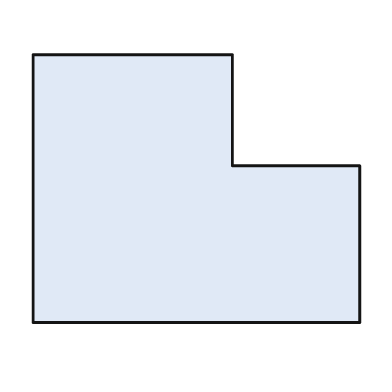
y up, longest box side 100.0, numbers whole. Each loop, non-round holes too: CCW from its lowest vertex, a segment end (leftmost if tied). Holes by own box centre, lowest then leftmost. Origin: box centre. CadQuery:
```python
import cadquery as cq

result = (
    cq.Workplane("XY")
    .moveTo(-50.0, -41.0)
    .lineTo(50.0, -41.0)
    .lineTo(50.0, 7.0)
    .lineTo(11.0, 7.0)
    .lineTo(11.0, 41.0)
    .lineTo(-50.0, 41.0)
    .close()
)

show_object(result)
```